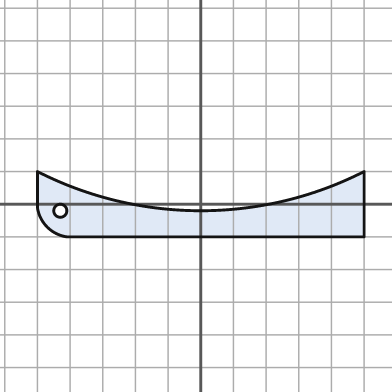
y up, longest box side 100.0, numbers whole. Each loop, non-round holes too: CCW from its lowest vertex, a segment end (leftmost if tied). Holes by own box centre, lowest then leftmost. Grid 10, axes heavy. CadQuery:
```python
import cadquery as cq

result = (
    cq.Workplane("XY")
    .moveTo(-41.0, -10.0)
    .lineTo(50.0, -10.0)
    .lineTo(50.0, 10.0)
    .threePointArc((0.0, -2.0), (-50.0, 10.0))
    .lineTo(-50.0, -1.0)
    .threePointArc((-47.0, -7.0), (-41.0, -10.0))
    .close()
    .moveTo(-43.0, -2.0)
    .circle(2.0)
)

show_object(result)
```